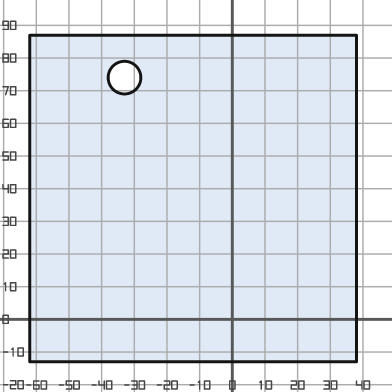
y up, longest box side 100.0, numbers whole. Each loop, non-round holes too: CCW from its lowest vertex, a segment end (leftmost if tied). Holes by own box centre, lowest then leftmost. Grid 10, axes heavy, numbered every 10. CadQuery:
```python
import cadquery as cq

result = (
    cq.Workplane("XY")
    .moveTo(-62.0, -13.0)
    .lineTo(38.0, -13.0)
    .lineTo(38.0, 87.0)
    .lineTo(-62.0, 87.0)
    .close()
    .moveTo(-33.0, 74.0)
    .circle(5.0)
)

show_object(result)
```